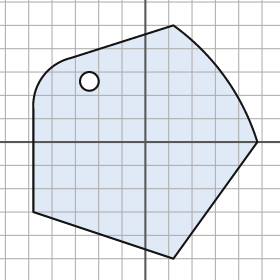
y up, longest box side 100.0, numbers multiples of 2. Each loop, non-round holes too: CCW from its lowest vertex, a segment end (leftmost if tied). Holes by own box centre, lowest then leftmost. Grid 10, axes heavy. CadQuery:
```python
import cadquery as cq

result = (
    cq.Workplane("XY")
    .moveTo(12.0, -50.0)
    .lineTo(48.0, 0.0)
    .threePointArc((34.0, 28.0), (12.0, 50.0))
    .lineTo(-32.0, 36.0)
    .threePointArc((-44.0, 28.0), (-48.0, 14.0))
    .lineTo(-48.0, -30.0)
    .close()
    .moveTo(-24.0, 26.0)
    .circle(4.0)
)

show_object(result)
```